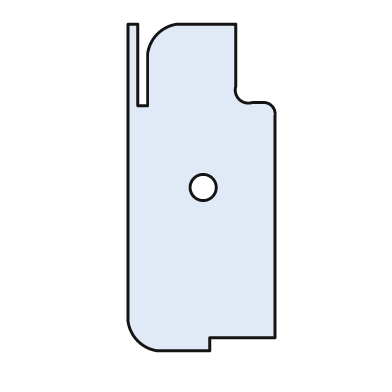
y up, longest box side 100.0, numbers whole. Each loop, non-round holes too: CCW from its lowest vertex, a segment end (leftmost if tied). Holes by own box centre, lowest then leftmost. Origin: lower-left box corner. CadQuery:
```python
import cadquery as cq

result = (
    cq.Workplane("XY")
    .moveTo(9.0, 0.0)
    .lineTo(25.0, 0.0)
    .lineTo(25.0, 4.0)
    .lineTo(45.0, 4.0)
    .lineTo(45.0, 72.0)
    .threePointArc((44.0, 75.0), (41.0, 76.0))
    .lineTo(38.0, 76.0)
    .threePointArc((34.0, 77.0), (33.0, 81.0))
    .lineTo(33.0, 100.0)
    .lineTo(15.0, 100.0)
    .threePointArc((9.0, 97.0), (6.0, 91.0))
    .lineTo(6.0, 75.0)
    .lineTo(3.0, 75.0)
    .lineTo(3.0, 100.0)
    .lineTo(0.0, 100.0)
    .lineTo(0.0, 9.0)
    .threePointArc((3.0, 3.0), (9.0, 0.0))
    .close()
    .moveTo(23.0, 50.0)
    .circle(4.0)
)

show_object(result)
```